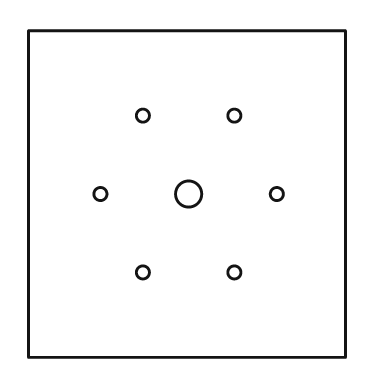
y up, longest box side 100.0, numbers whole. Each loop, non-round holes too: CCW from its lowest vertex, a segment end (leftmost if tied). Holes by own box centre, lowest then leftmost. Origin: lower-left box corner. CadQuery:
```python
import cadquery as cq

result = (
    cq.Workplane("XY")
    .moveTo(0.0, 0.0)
    .lineTo(97.0, 0.0)
    .lineTo(97.0, 100.0)
    .lineTo(0.0, 100.0)
    .close()
    .moveTo(35.0, 26.0)
    .circle(2.0)
    .moveTo(63.0, 26.0)
    .circle(2.0)
    .moveTo(22.0, 50.0)
    .circle(2.0)
    .moveTo(49.0, 50.0)
    .circle(4.0)
    .moveTo(76.0, 50.0)
    .circle(2.0)
    .moveTo(35.0, 74.0)
    .circle(2.0)
    .moveTo(63.0, 74.0)
    .circle(2.0)
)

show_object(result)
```